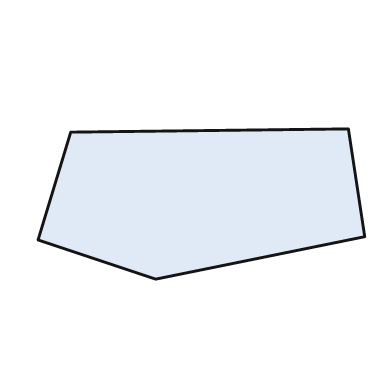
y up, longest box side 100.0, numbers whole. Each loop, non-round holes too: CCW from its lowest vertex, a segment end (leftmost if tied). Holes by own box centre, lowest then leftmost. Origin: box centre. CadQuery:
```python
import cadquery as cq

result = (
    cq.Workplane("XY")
    .moveTo(-14.0, -23.0)
    .lineTo(50.0, -10.0)
    .lineTo(45.0, 23.0)
    .lineTo(-40.0, 22.0)
    .lineTo(-50.0, -11.0)
    .close()
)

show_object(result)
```